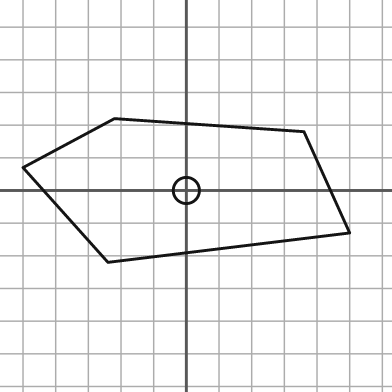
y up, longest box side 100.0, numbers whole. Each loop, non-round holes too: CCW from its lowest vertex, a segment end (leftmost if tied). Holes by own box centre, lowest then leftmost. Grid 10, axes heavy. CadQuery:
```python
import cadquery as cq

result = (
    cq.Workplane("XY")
    .moveTo(-24.0, -22.0)
    .lineTo(50.0, -13.0)
    .lineTo(36.0, 18.0)
    .lineTo(-22.0, 22.0)
    .lineTo(-50.0, 7.0)
    .close()
    .moveTo(0.0, 0.0)
    .circle(4.0)
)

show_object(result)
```